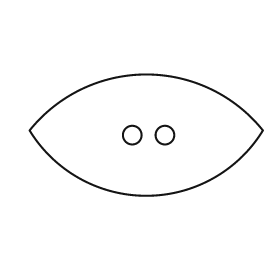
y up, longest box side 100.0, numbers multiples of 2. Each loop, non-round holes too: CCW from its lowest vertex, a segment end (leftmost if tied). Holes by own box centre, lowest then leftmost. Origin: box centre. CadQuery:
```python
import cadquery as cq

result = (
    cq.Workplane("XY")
    .moveTo(-50.0, 2.0)
    .threePointArc((0.0, -26.0), (50.0, 2.0))
    .threePointArc((0.0, 26.0), (-50.0, 2.0))
    .close()
    .moveTo(-6.0, 0.0)
    .circle(4.0)
    .moveTo(8.0, 0.0)
    .circle(4.0)
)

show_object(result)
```